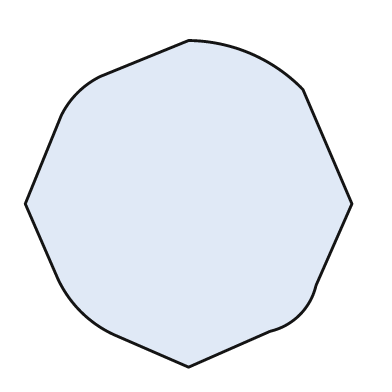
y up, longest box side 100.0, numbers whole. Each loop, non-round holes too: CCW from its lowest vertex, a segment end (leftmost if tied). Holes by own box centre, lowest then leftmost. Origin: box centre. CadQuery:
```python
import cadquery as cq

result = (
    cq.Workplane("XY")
    .moveTo(0.0, -50.0)
    .lineTo(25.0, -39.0)
    .threePointArc((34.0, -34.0), (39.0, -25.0))
    .lineTo(50.0, 0.0)
    .lineTo(35.0, 35.0)
    .threePointArc((19.0, 46.0), (0.0, 50.0))
    .lineTo(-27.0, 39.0)
    .threePointArc((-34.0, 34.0), (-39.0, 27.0))
    .lineTo(-50.0, 0.0)
    .lineTo(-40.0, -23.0)
    .threePointArc((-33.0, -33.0), (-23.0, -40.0))
    .close()
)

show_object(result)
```